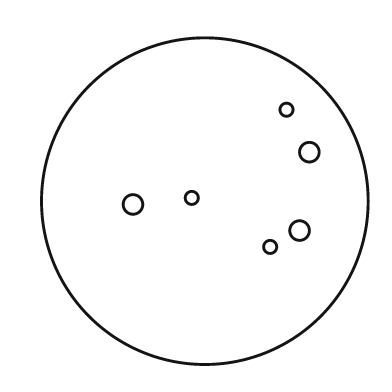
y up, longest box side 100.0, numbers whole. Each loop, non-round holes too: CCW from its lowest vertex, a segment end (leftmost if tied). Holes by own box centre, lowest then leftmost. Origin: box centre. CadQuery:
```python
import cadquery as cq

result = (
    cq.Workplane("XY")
    .moveTo(0.0, 0.0)
    .circle(50.0)
    .moveTo(20.0, -14.0)
    .circle(2.0)
    .moveTo(29.0, -9.0)
    .circle(3.0)
    .moveTo(-22.0, -1.0)
    .circle(3.0)
    .moveTo(-4.0, 1.0)
    .circle(2.0)
    .moveTo(32.0, 15.0)
    .circle(3.0)
    .moveTo(25.0, 28.0)
    .circle(2.0)
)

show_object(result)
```